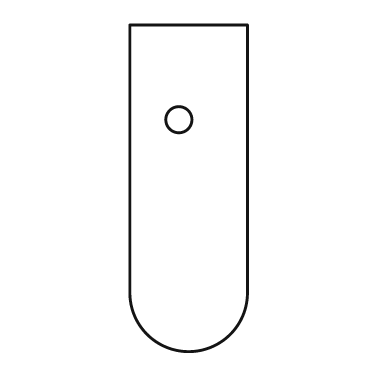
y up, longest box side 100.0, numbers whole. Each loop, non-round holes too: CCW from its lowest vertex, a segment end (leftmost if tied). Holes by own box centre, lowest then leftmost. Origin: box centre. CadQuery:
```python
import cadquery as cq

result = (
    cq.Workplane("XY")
    .moveTo(-18.0, -32.0)
    .threePointArc((0.0, -50.0), (18.0, -32.0))
    .lineTo(18.0, 50.0)
    .lineTo(-18.0, 50.0)
    .close()
    .moveTo(-3.0, 21.0)
    .circle(4.0)
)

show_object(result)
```